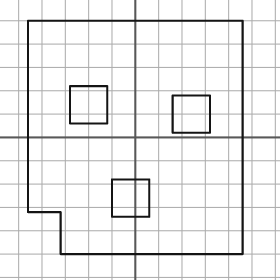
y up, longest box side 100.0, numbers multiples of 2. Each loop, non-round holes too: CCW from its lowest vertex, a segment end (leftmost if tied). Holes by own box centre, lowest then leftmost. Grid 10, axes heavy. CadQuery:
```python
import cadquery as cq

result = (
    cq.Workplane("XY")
    .moveTo(-32.0, -50.0)
    .lineTo(46.0, -50.0)
    .lineTo(46.0, 50.0)
    .lineTo(-46.0, 50.0)
    .lineTo(-46.0, -32.0)
    .lineTo(-32.0, -32.0)
    .close()
    .moveTo(-10.0, -34.0)
    .lineTo(6.0, -34.0)
    .lineTo(6.0, -18.0)
    .lineTo(-10.0, -18.0)
    .close()
    .moveTo(16.0, 2.0)
    .lineTo(32.0, 2.0)
    .lineTo(32.0, 18.0)
    .lineTo(16.0, 18.0)
    .close()
    .moveTo(-28.0, 6.0)
    .lineTo(-12.0, 6.0)
    .lineTo(-12.0, 22.0)
    .lineTo(-28.0, 22.0)
    .close()
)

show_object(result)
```